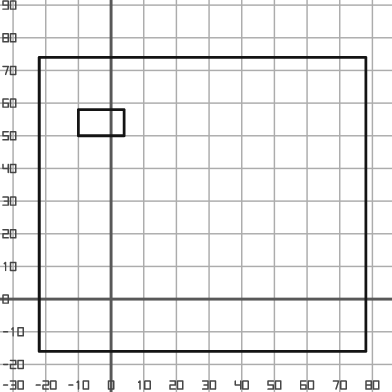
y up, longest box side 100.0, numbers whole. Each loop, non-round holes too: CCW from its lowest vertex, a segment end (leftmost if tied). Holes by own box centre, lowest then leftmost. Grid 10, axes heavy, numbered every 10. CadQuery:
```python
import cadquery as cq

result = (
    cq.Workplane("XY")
    .moveTo(-22.0, -16.0)
    .lineTo(78.0, -16.0)
    .lineTo(78.0, 74.0)
    .lineTo(-22.0, 74.0)
    .close()
    .moveTo(-10.0, 50.0)
    .lineTo(4.0, 50.0)
    .lineTo(4.0, 58.0)
    .lineTo(-10.0, 58.0)
    .close()
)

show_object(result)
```